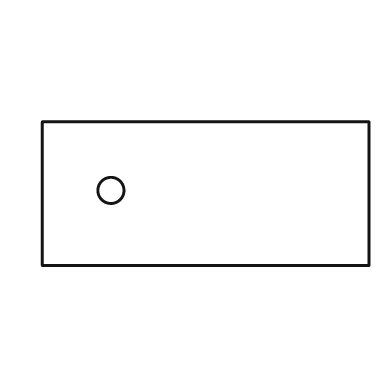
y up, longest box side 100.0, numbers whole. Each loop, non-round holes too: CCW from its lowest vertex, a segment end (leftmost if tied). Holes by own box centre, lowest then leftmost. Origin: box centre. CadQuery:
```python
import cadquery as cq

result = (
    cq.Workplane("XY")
    .moveTo(-50.0, -22.0)
    .lineTo(50.0, -22.0)
    .lineTo(50.0, 22.0)
    .lineTo(-50.0, 22.0)
    .close()
    .moveTo(-29.0, 1.0)
    .circle(4.0)
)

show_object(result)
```